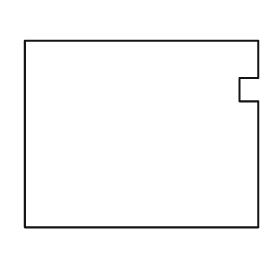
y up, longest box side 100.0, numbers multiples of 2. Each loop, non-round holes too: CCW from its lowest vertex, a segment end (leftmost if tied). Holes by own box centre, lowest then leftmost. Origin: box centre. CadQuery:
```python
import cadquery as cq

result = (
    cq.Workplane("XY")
    .moveTo(-50.0, -40.0)
    .lineTo(50.0, -40.0)
    .lineTo(50.0, 14.0)
    .lineTo(42.0, 14.0)
    .lineTo(42.0, 24.0)
    .lineTo(50.0, 24.0)
    .lineTo(50.0, 40.0)
    .lineTo(-50.0, 40.0)
    .close()
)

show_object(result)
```